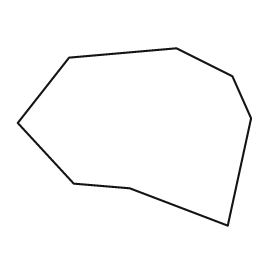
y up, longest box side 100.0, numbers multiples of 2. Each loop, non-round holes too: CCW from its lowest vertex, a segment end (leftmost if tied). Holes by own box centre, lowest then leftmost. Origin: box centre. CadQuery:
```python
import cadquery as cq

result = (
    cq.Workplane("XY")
    .moveTo(40.0, -38.0)
    .lineTo(50.0, 8.0)
    .lineTo(42.0, 26.0)
    .lineTo(18.0, 38.0)
    .lineTo(-28.0, 34.0)
    .lineTo(-50.0, 6.0)
    .lineTo(-26.0, -20.0)
    .lineTo(-2.0, -22.0)
    .close()
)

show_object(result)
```